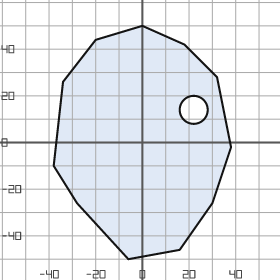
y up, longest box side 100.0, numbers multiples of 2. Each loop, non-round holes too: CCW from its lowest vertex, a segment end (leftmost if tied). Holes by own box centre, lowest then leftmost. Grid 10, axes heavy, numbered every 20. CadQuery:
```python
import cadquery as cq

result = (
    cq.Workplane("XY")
    .moveTo(-6.0, -50.0)
    .lineTo(16.0, -46.0)
    .lineTo(30.0, -26.0)
    .lineTo(38.0, -2.0)
    .lineTo(32.0, 28.0)
    .lineTo(18.0, 42.0)
    .lineTo(0.0, 50.0)
    .lineTo(-20.0, 44.0)
    .lineTo(-34.0, 26.0)
    .lineTo(-38.0, -10.0)
    .lineTo(-28.0, -26.0)
    .close()
    .moveTo(22.0, 14.0)
    .circle(6.0)
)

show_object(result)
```